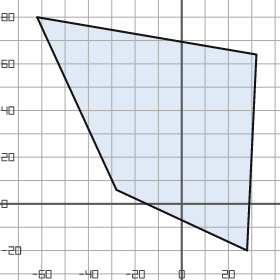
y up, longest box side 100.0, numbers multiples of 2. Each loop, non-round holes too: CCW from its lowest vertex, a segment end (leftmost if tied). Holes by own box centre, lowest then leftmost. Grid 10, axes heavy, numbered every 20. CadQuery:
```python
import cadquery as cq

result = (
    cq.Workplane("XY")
    .moveTo(28.0, -20.0)
    .lineTo(32.0, 64.0)
    .lineTo(-62.0, 80.0)
    .lineTo(-28.0, 6.0)
    .close()
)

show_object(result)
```